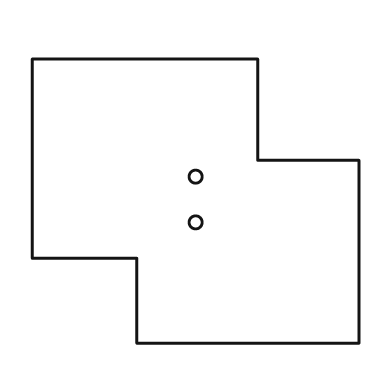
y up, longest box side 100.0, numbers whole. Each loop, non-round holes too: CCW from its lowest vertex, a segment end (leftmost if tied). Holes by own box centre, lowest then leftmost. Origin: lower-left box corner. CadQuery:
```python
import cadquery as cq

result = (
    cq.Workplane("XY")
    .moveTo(32.0, 0.0)
    .lineTo(100.0, 0.0)
    .lineTo(100.0, 56.0)
    .lineTo(69.0, 56.0)
    .lineTo(69.0, 87.0)
    .lineTo(0.0, 87.0)
    .lineTo(0.0, 26.0)
    .lineTo(32.0, 26.0)
    .close()
    .moveTo(50.0, 37.0)
    .circle(2.0)
    .moveTo(50.0, 51.0)
    .circle(2.0)
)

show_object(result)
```